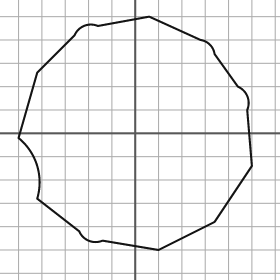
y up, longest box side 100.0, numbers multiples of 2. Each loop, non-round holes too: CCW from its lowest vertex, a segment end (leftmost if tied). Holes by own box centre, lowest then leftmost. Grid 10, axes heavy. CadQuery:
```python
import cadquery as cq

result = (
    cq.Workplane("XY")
    .moveTo(10.0, -50.0)
    .lineTo(34.0, -38.0)
    .lineTo(50.0, -14.0)
    .lineTo(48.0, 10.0)
    .threePointArc((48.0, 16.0), (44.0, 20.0))
    .lineTo(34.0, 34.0)
    .threePointArc((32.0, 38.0), (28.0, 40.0))
    .lineTo(6.0, 50.0)
    .lineTo(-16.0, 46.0)
    .threePointArc((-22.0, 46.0), (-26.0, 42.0))
    .lineTo(-42.0, 26.0)
    .lineTo(-50.0, -2.0)
    .threePointArc((-42.0, -14.0), (-42.0, -28.0))
    .lineTo(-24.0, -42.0)
    .threePointArc((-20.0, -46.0), (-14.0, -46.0))
    .close()
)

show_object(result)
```